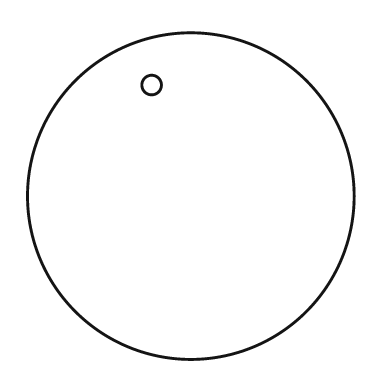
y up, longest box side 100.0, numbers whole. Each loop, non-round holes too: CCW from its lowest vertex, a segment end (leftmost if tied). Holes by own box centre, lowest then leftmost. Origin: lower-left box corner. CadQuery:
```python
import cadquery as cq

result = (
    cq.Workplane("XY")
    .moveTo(50.0, 50.0)
    .circle(50.0)
    .moveTo(38.0, 84.0)
    .circle(3.0)
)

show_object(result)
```